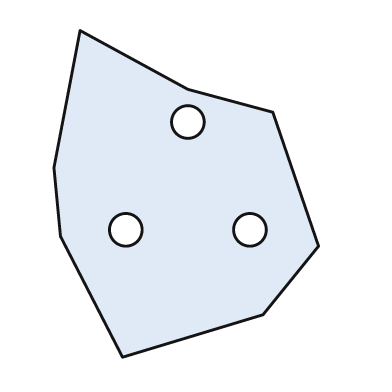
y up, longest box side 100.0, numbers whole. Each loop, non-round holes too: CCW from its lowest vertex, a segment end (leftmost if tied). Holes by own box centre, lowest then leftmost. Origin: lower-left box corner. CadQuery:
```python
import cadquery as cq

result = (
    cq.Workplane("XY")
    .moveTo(21.0, 0.0)
    .lineTo(64.0, 13.0)
    .lineTo(81.0, 34.0)
    .lineTo(67.0, 75.0)
    .lineTo(41.0, 82.0)
    .lineTo(8.0, 100.0)
    .lineTo(0.0, 58.0)
    .lineTo(2.0, 37.0)
    .close()
    .moveTo(22.0, 39.0)
    .circle(5.0)
    .moveTo(60.0, 39.0)
    .circle(5.0)
    .moveTo(41.0, 72.0)
    .circle(5.0)
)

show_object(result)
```